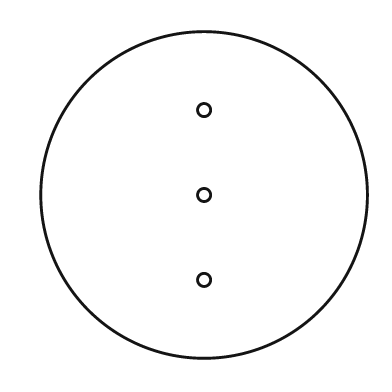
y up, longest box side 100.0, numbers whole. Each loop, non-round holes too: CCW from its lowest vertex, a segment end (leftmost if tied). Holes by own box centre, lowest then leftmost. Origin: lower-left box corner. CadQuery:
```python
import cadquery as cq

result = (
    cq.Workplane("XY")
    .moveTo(50.0, 50.0)
    .circle(50.0)
    .moveTo(50.0, 24.0)
    .circle(2.0)
    .moveTo(50.0, 50.0)
    .circle(2.0)
    .moveTo(50.0, 76.0)
    .circle(2.0)
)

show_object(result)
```